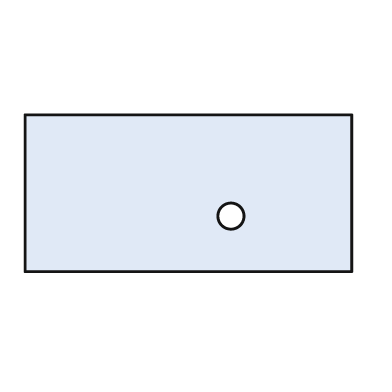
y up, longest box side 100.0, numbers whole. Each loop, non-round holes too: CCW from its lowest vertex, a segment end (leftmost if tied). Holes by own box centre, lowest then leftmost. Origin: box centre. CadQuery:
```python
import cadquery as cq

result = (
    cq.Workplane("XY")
    .moveTo(-50.0, -24.0)
    .lineTo(50.0, -24.0)
    .lineTo(50.0, 24.0)
    .lineTo(-50.0, 24.0)
    .close()
    .moveTo(13.0, -7.0)
    .circle(4.0)
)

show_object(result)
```